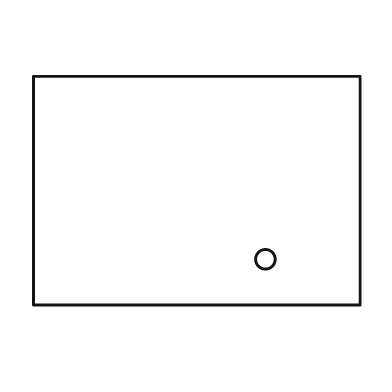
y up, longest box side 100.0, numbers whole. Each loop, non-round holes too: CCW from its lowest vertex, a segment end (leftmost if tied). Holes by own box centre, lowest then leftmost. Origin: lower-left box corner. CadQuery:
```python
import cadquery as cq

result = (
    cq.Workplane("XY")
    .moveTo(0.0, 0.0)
    .lineTo(100.0, 0.0)
    .lineTo(100.0, 70.0)
    .lineTo(0.0, 70.0)
    .close()
    .moveTo(71.0, 14.0)
    .circle(3.0)
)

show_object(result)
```